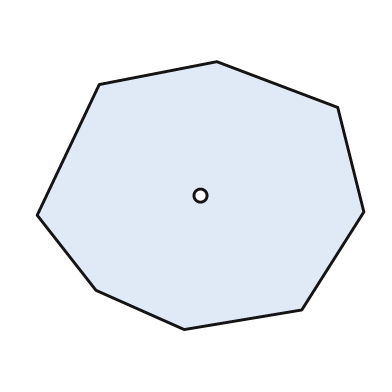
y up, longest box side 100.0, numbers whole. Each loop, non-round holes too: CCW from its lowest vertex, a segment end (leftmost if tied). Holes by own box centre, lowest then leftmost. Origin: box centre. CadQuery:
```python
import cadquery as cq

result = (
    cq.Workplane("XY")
    .moveTo(-5.0, -41.0)
    .lineTo(31.0, -35.0)
    .lineTo(50.0, -5.0)
    .lineTo(42.0, 27.0)
    .lineTo(5.0, 41.0)
    .lineTo(-31.0, 34.0)
    .lineTo(-50.0, -6.0)
    .lineTo(-32.0, -29.0)
    .close()
    .moveTo(0.0, 0.0)
    .circle(2.0)
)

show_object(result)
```